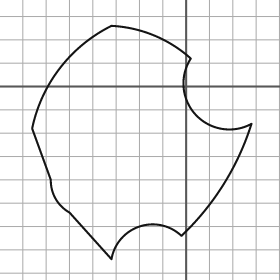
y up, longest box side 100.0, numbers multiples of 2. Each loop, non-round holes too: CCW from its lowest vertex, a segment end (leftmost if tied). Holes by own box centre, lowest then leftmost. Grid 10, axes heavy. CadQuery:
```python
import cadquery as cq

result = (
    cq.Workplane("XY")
    .moveTo(-32.0, -74.0)
    .threePointArc((-20.0, -60.0), (-2.0, -64.0))
    .threePointArc((16.0, -42.0), (28.0, -16.0))
    .threePointArc((4.0, -12.0), (2.0, 12.0))
    .threePointArc((-14.0, 22.0), (-32.0, 26.0))
    .threePointArc((-54.0, 8.0), (-66.0, -18.0))
    .lineTo(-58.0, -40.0)
    .threePointArc((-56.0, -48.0), (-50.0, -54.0))
    .close()
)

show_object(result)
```